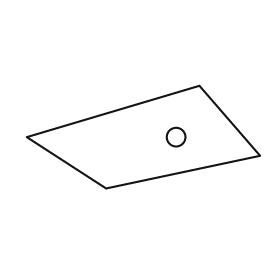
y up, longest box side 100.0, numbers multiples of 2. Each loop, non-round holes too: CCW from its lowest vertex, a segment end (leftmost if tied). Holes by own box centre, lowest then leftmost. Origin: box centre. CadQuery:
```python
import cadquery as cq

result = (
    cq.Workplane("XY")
    .moveTo(-16.0, -22.0)
    .lineTo(50.0, -8.0)
    .lineTo(24.0, 22.0)
    .lineTo(-50.0, 0.0)
    .close()
    .moveTo(14.0, 0.0)
    .circle(4.0)
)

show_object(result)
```